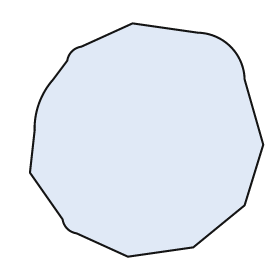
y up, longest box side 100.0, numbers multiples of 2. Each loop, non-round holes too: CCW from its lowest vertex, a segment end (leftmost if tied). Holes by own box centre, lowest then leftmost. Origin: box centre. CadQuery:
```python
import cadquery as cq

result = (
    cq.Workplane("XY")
    .moveTo(-8.0, -50.0)
    .lineTo(20.0, -46.0)
    .lineTo(42.0, -28.0)
    .lineTo(50.0, -2.0)
    .lineTo(42.0, 26.0)
    .threePointArc((36.0, 40.0), (22.0, 46.0))
    .lineTo(-6.0, 50.0)
    .lineTo(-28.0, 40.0)
    .threePointArc((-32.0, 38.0), (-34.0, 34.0))
    .lineTo(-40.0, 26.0)
    .threePointArc((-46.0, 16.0), (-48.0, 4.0))
    .lineTo(-50.0, -14.0)
    .lineTo(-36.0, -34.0)
    .threePointArc((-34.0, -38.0), (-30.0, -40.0))
    .close()
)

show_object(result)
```